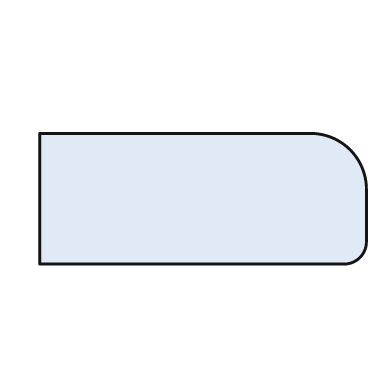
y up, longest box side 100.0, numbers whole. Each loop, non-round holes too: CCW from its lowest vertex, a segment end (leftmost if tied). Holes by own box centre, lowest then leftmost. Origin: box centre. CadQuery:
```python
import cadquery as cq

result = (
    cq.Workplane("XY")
    .moveTo(-50.0, -20.0)
    .lineTo(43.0, -20.0)
    .threePointArc((48.0, -18.0), (50.0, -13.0))
    .lineTo(50.0, 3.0)
    .threePointArc((45.0, 15.0), (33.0, 20.0))
    .lineTo(-50.0, 20.0)
    .close()
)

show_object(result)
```